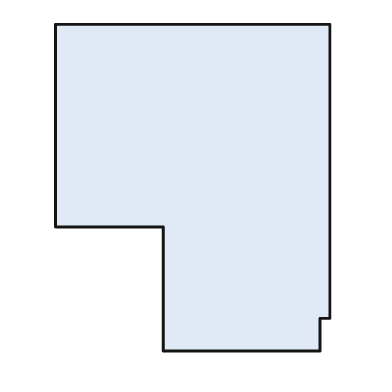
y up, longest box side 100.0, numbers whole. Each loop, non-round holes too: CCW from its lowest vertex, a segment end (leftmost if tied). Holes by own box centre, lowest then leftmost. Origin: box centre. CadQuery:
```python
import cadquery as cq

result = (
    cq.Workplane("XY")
    .moveTo(-9.0, -50.0)
    .lineTo(39.0, -50.0)
    .lineTo(39.0, -40.0)
    .lineTo(42.0, -40.0)
    .lineTo(42.0, 50.0)
    .lineTo(-42.0, 50.0)
    .lineTo(-42.0, -12.0)
    .lineTo(-9.0, -12.0)
    .close()
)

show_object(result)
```